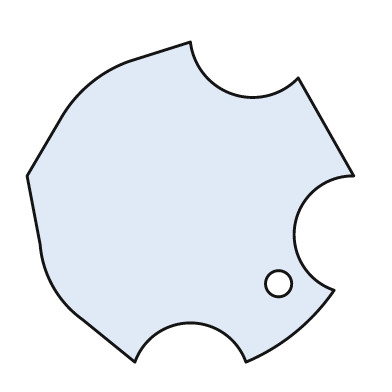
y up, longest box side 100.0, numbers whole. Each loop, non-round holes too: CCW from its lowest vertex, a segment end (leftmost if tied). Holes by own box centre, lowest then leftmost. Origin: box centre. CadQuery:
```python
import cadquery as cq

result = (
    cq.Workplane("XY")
    .moveTo(-17.0, -49.0)
    .threePointArc((0.0, -37.0), (17.0, -49.0))
    .threePointArc((32.0, -40.0), (44.0, -27.0))
    .threePointArc((32.0, -7.0), (50.0, 8.0))
    .lineTo(33.0, 38.0)
    .threePointArc((13.0, 33.0), (0.0, 49.0))
    .lineTo(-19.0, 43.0)
    .threePointArc((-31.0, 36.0), (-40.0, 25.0))
    .lineTo(-50.0, 8.0)
    .lineTo(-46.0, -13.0)
    .threePointArc((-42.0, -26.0), (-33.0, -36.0))
    .close()
    .moveTo(27.0, -25.0)
    .circle(4.0)
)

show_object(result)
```